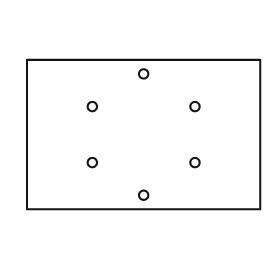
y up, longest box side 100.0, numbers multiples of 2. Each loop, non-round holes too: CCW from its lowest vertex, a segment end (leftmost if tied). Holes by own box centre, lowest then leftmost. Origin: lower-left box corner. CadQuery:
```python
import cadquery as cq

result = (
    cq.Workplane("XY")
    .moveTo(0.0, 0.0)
    .lineTo(100.0, 0.0)
    .lineTo(100.0, 64.0)
    .lineTo(0.0, 64.0)
    .close()
    .moveTo(50.0, 6.0)
    .circle(2.0)
    .moveTo(28.0, 20.0)
    .circle(2.0)
    .moveTo(72.0, 20.0)
    .circle(2.0)
    .moveTo(28.0, 44.0)
    .circle(2.0)
    .moveTo(72.0, 44.0)
    .circle(2.0)
    .moveTo(50.0, 58.0)
    .circle(2.0)
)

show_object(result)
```